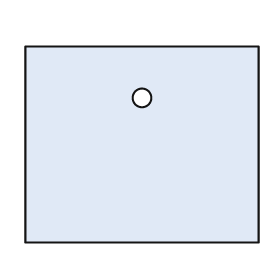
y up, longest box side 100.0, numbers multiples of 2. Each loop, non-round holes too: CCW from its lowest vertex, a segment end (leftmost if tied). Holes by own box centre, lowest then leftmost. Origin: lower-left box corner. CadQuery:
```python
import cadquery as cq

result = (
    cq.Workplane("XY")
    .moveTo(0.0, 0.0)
    .lineTo(100.0, 0.0)
    .lineTo(100.0, 84.0)
    .lineTo(0.0, 84.0)
    .close()
    .moveTo(50.0, 62.0)
    .circle(4.0)
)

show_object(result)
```